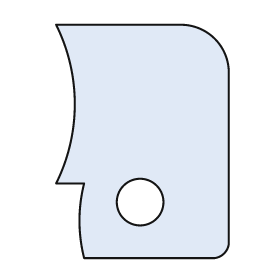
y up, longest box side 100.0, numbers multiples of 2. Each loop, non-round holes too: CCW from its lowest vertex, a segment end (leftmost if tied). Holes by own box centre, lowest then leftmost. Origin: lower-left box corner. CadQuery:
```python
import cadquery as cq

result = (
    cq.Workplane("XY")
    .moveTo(12.0, 0.0)
    .lineTo(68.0, 0.0)
    .threePointArc((72.0, 2.0), (74.0, 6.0))
    .lineTo(74.0, 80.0)
    .threePointArc((68.0, 94.0), (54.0, 100.0))
    .lineTo(0.0, 100.0)
    .threePointArc((8.0, 66.0), (0.0, 32.0))
    .lineTo(12.0, 32.0)
    .threePointArc((10.0, 16.0), (12.0, 0.0))
    .close()
    .moveTo(36.0, 24.0)
    .circle(10.0)
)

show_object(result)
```